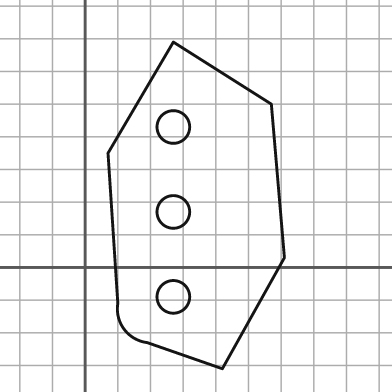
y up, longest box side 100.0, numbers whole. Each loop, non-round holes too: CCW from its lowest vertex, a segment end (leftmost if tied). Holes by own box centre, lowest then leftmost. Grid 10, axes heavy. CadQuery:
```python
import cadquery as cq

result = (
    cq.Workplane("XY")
    .moveTo(42.0, -31.0)
    .lineTo(61.0, 3.0)
    .lineTo(57.0, 50.0)
    .lineTo(27.0, 69.0)
    .lineTo(7.0, 35.0)
    .lineTo(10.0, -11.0)
    .threePointArc((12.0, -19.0), (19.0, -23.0))
    .close()
    .moveTo(27.0, -9.0)
    .circle(5.0)
    .moveTo(27.0, 17.0)
    .circle(5.0)
    .moveTo(27.0, 43.0)
    .circle(5.0)
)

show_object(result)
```